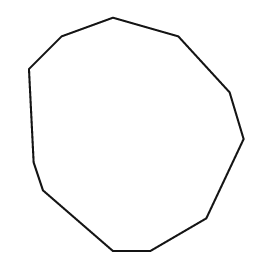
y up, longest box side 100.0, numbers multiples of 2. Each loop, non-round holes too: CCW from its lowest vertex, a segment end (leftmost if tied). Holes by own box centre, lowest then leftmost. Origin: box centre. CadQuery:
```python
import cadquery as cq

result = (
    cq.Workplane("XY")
    .moveTo(-10.0, -50.0)
    .lineTo(6.0, -50.0)
    .lineTo(30.0, -36.0)
    .lineTo(46.0, -2.0)
    .lineTo(40.0, 18.0)
    .lineTo(18.0, 42.0)
    .lineTo(-10.0, 50.0)
    .lineTo(-32.0, 42.0)
    .lineTo(-46.0, 28.0)
    .lineTo(-44.0, -12.0)
    .lineTo(-40.0, -24.0)
    .close()
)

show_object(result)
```